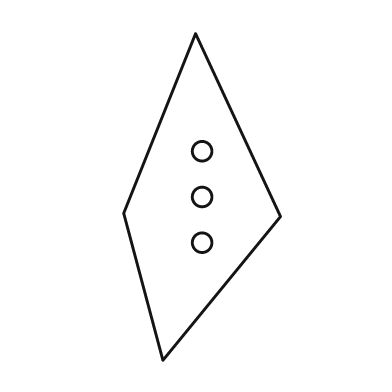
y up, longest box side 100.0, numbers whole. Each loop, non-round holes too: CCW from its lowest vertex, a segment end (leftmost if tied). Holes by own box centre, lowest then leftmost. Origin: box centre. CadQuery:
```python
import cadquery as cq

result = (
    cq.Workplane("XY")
    .moveTo(-12.0, -50.0)
    .lineTo(24.0, -6.0)
    .lineTo(-2.0, 50.0)
    .lineTo(-24.0, -5.0)
    .close()
    .moveTo(0.0, -14.0)
    .circle(3.0)
    .moveTo(0.0, 0.0)
    .circle(3.0)
    .moveTo(0.0, 14.0)
    .circle(3.0)
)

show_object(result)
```